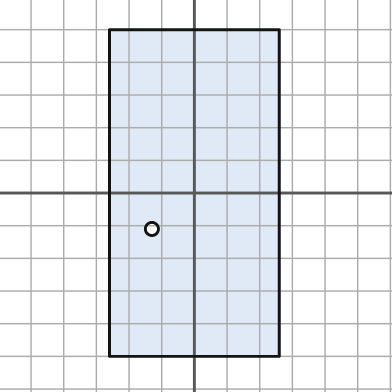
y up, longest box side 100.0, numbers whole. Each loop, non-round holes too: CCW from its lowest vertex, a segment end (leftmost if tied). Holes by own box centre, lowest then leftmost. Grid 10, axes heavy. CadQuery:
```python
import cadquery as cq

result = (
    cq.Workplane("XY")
    .moveTo(-26.0, -50.0)
    .lineTo(26.0, -50.0)
    .lineTo(26.0, 50.0)
    .lineTo(-26.0, 50.0)
    .close()
    .moveTo(-13.0, -11.0)
    .circle(2.0)
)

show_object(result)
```